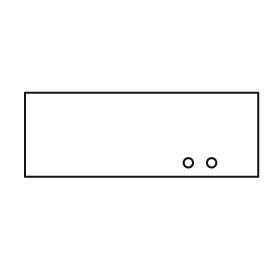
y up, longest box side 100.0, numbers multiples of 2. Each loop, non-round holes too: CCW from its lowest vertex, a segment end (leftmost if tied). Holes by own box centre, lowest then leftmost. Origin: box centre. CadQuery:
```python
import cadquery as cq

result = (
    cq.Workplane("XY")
    .moveTo(-50.0, -18.0)
    .lineTo(50.0, -18.0)
    .lineTo(50.0, 18.0)
    .lineTo(-50.0, 18.0)
    .close()
    .moveTo(20.0, -12.0)
    .circle(2.0)
    .moveTo(30.0, -12.0)
    .circle(2.0)
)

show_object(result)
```